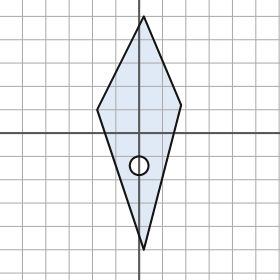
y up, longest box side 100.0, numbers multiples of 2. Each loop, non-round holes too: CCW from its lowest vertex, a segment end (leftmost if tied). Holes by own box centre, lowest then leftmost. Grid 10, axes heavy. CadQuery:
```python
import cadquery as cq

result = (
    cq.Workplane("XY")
    .moveTo(2.0, -50.0)
    .lineTo(18.0, 12.0)
    .lineTo(2.0, 50.0)
    .lineTo(-18.0, 10.0)
    .close()
    .moveTo(0.0, -14.0)
    .circle(4.0)
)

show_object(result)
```